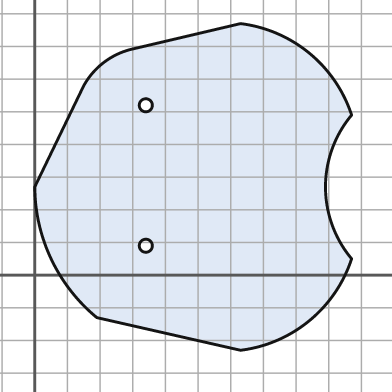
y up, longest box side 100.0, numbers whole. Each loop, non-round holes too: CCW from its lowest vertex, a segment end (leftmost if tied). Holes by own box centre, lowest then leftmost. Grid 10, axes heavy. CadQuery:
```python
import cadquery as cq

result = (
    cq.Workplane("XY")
    .moveTo(63.0, -23.0)
    .threePointArc((84.0, -14.0), (97.0, 5.0))
    .threePointArc((89.0, 27.0), (97.0, 49.0))
    .threePointArc((84.0, 68.0), (63.0, 77.0))
    .lineTo(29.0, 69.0)
    .threePointArc((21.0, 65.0), (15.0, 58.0))
    .lineTo(0.0, 27.0)
    .threePointArc((5.0, 5.0), (19.0, -13.0))
    .close()
    .moveTo(34.0, 9.0)
    .circle(2.0)
    .moveTo(34.0, 52.0)
    .circle(2.0)
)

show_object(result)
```